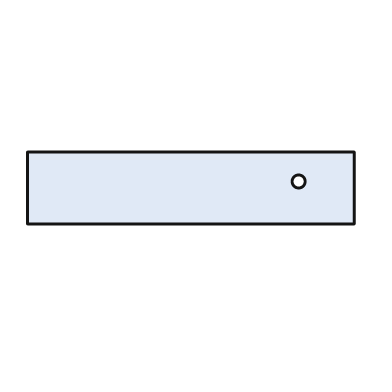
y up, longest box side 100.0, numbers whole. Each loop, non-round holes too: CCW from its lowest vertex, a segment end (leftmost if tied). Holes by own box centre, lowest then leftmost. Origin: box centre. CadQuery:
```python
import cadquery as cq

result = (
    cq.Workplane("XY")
    .moveTo(-50.0, -11.0)
    .lineTo(50.0, -11.0)
    .lineTo(50.0, 11.0)
    .lineTo(-50.0, 11.0)
    .close()
    .moveTo(33.0, 2.0)
    .circle(2.0)
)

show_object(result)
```